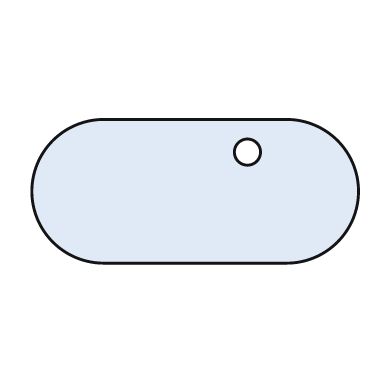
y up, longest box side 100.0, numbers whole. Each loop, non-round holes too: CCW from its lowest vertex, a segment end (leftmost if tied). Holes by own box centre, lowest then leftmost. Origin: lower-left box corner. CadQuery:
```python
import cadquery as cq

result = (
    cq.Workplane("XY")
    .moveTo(22.0, 0.0)
    .lineTo(78.0, 0.0)
    .threePointArc((100.0, 22.0), (78.0, 44.0))
    .lineTo(22.0, 44.0)
    .threePointArc((0.0, 22.0), (22.0, 0.0))
    .close()
    .moveTo(66.0, 34.0)
    .circle(4.0)
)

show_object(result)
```